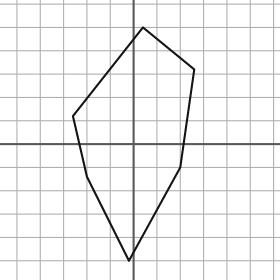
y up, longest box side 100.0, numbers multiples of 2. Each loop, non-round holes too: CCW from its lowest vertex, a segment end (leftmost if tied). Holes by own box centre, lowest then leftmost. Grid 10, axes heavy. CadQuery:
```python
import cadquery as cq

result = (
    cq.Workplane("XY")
    .moveTo(-2.0, -50.0)
    .lineTo(20.0, -10.0)
    .lineTo(26.0, 32.0)
    .lineTo(4.0, 50.0)
    .lineTo(-26.0, 12.0)
    .lineTo(-20.0, -14.0)
    .close()
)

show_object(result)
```